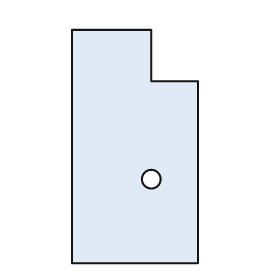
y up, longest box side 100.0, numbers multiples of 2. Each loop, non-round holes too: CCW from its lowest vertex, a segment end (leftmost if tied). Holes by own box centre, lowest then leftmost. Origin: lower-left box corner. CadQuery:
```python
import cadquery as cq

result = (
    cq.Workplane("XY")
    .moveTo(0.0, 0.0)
    .lineTo(54.0, 0.0)
    .lineTo(54.0, 78.0)
    .lineTo(34.0, 78.0)
    .lineTo(34.0, 100.0)
    .lineTo(0.0, 100.0)
    .close()
    .moveTo(34.0, 36.0)
    .circle(4.0)
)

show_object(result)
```